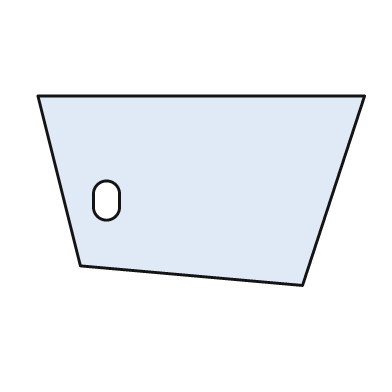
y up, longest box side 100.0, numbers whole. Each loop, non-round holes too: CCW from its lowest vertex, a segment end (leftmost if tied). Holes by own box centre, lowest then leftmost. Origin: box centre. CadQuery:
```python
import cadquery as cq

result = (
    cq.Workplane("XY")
    .moveTo(31.0, -29.0)
    .lineTo(50.0, 29.0)
    .lineTo(-50.0, 29.0)
    .lineTo(-37.0, -23.0)
    .close()
    .moveTo(-33.0, -5.0)
    .threePointArc((-29.0, -9.0), (-25.0, -5.0))
    .lineTo(-25.0, -1.0)
    .threePointArc((-29.0, 3.0), (-33.0, -1.0))
    .close()
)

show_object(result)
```